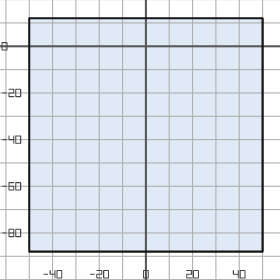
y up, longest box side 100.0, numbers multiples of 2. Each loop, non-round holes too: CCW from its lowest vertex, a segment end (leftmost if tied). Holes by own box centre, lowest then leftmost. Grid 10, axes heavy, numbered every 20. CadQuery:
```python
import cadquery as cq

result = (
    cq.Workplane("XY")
    .moveTo(-50.0, -88.0)
    .lineTo(50.0, -88.0)
    .lineTo(50.0, 12.0)
    .lineTo(-50.0, 12.0)
    .close()
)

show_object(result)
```